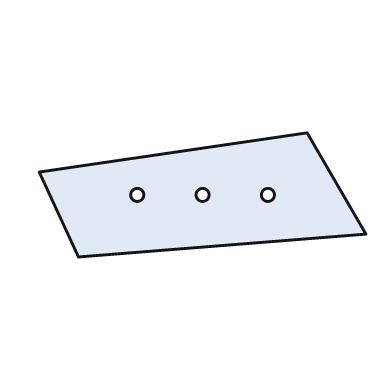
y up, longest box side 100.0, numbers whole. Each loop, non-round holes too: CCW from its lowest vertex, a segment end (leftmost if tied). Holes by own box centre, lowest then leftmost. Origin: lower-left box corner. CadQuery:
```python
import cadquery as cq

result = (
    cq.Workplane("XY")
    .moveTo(12.0, 0.0)
    .lineTo(100.0, 7.0)
    .lineTo(82.0, 38.0)
    .lineTo(0.0, 26.0)
    .close()
    .moveTo(30.0, 19.0)
    .circle(2.0)
    .moveTo(50.0, 19.0)
    .circle(2.0)
    .moveTo(70.0, 19.0)
    .circle(2.0)
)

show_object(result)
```